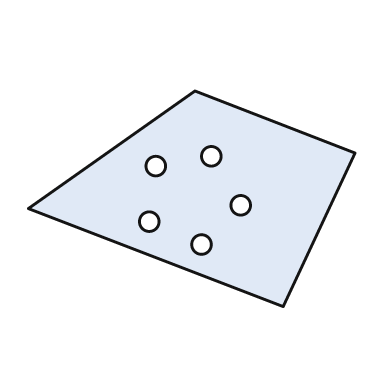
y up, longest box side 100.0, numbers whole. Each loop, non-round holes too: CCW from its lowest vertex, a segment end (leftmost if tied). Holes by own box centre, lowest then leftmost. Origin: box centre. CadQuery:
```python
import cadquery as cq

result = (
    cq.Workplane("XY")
    .moveTo(28.0, -33.0)
    .lineTo(50.0, 14.0)
    .lineTo(1.0, 33.0)
    .lineTo(-50.0, -3.0)
    .close()
    .moveTo(3.0, -14.0)
    .circle(3.0)
    .moveTo(-13.0, -7.0)
    .circle(3.0)
    .moveTo(15.0, -2.0)
    .circle(3.0)
    .moveTo(-11.0, 10.0)
    .circle(3.0)
    .moveTo(6.0, 13.0)
    .circle(3.0)
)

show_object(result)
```